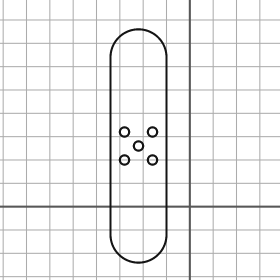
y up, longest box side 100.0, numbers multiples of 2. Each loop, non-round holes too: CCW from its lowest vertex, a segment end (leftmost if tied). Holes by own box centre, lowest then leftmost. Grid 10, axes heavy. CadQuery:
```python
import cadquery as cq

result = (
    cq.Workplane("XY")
    .moveTo(-34.0, -12.0)
    .threePointArc((-22.0, -24.0), (-10.0, -12.0))
    .lineTo(-10.0, 64.0)
    .threePointArc((-22.0, 76.0), (-34.0, 64.0))
    .close()
    .moveTo(-28.0, 20.0)
    .circle(2.0)
    .moveTo(-16.0, 20.0)
    .circle(2.0)
    .moveTo(-22.0, 26.0)
    .circle(2.0)
    .moveTo(-28.0, 32.0)
    .circle(2.0)
    .moveTo(-16.0, 32.0)
    .circle(2.0)
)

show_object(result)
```